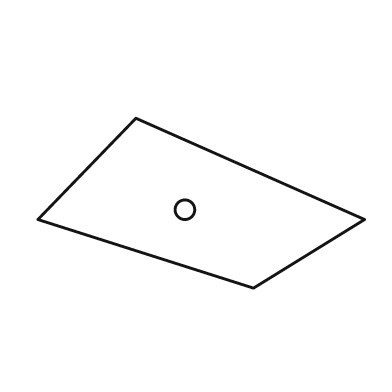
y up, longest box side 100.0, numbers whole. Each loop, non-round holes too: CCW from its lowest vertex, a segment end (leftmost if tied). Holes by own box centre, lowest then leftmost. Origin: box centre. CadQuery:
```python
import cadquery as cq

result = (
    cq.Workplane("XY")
    .moveTo(16.0, -26.0)
    .lineTo(50.0, -5.0)
    .lineTo(-20.0, 26.0)
    .lineTo(-50.0, -5.0)
    .close()
    .moveTo(-5.0, -2.0)
    .circle(3.0)
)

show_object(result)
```